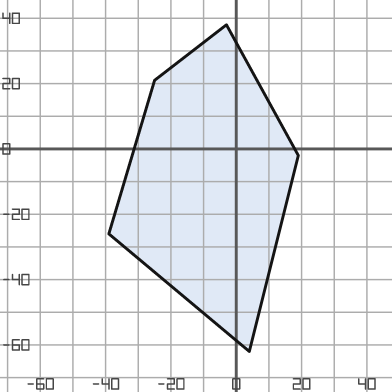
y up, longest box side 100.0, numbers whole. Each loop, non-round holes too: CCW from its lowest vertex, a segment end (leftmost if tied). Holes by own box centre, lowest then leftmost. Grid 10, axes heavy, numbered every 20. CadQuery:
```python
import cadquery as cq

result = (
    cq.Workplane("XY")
    .moveTo(4.0, -62.0)
    .lineTo(19.0, -2.0)
    .lineTo(-3.0, 38.0)
    .lineTo(-25.0, 21.0)
    .lineTo(-39.0, -26.0)
    .close()
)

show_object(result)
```